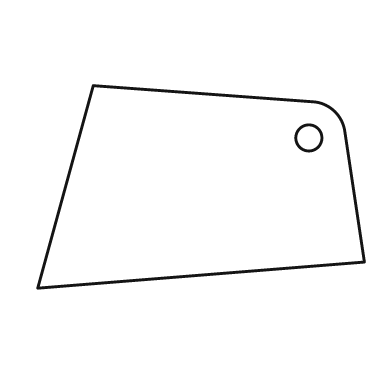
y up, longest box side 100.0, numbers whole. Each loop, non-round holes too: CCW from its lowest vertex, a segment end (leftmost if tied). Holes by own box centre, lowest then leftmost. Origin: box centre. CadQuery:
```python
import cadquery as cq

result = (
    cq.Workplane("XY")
    .moveTo(-50.0, -31.0)
    .lineTo(50.0, -23.0)
    .lineTo(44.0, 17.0)
    .threePointArc((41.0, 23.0), (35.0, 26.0))
    .lineTo(-33.0, 31.0)
    .close()
    .moveTo(33.0, 15.0)
    .circle(4.0)
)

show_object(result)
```